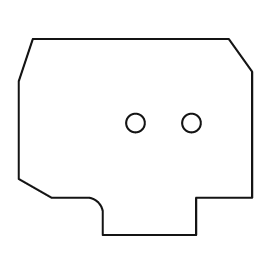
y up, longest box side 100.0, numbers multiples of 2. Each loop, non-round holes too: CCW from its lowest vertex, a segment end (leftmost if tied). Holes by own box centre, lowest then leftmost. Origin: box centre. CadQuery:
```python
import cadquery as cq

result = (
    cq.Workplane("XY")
    .moveTo(-14.0, -42.0)
    .lineTo(26.0, -42.0)
    .lineTo(26.0, -26.0)
    .lineTo(50.0, -26.0)
    .lineTo(50.0, 28.0)
    .lineTo(40.0, 42.0)
    .lineTo(-44.0, 42.0)
    .lineTo(-50.0, 24.0)
    .lineTo(-50.0, -18.0)
    .lineTo(-36.0, -26.0)
    .lineTo(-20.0, -26.0)
    .threePointArc((-16.0, -28.0), (-14.0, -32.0))
    .close()
    .moveTo(0.0, 6.0)
    .circle(4.0)
    .moveTo(24.0, 6.0)
    .circle(4.0)
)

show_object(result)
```